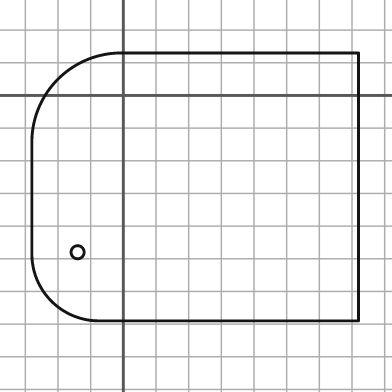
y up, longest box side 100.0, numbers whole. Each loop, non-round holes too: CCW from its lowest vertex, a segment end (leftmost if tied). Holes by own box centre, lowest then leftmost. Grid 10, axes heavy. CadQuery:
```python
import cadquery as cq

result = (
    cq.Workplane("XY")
    .moveTo(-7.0, -69.0)
    .lineTo(72.0, -69.0)
    .lineTo(72.0, 13.0)
    .lineTo(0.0, 13.0)
    .threePointArc((-20.0, 5.0), (-28.0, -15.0))
    .lineTo(-28.0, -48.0)
    .threePointArc((-22.0, -63.0), (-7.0, -69.0))
    .close()
    .moveTo(-14.0, -48.0)
    .circle(2.0)
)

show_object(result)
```